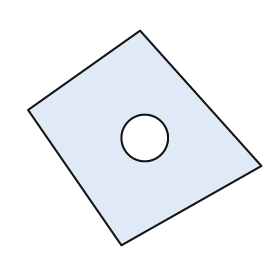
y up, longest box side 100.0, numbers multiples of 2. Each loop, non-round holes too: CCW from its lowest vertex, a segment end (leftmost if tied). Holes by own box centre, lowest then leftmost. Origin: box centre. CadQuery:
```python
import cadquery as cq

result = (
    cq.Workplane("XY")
    .moveTo(-10.0, -46.0)
    .lineTo(50.0, -12.0)
    .lineTo(-2.0, 46.0)
    .lineTo(-50.0, 12.0)
    .close()
    .moveTo(0.0, 0.0)
    .circle(10.0)
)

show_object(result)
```